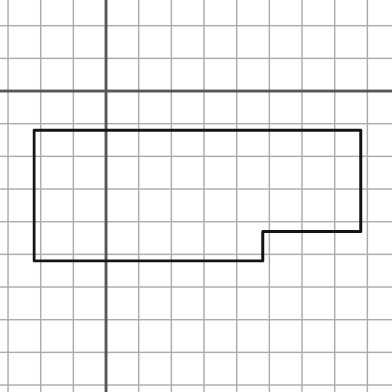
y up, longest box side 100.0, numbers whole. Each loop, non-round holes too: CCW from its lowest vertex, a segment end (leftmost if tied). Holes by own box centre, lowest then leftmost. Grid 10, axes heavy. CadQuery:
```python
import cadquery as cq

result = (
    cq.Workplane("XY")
    .moveTo(-22.0, -52.0)
    .lineTo(48.0, -52.0)
    .lineTo(48.0, -43.0)
    .lineTo(78.0, -43.0)
    .lineTo(78.0, -12.0)
    .lineTo(-22.0, -12.0)
    .close()
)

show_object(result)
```